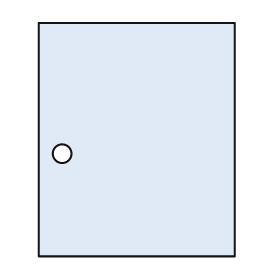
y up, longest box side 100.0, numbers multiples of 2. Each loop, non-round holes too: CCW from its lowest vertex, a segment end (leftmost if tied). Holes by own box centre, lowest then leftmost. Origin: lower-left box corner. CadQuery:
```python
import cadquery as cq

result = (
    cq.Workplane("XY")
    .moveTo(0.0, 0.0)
    .lineTo(84.0, 0.0)
    .lineTo(84.0, 100.0)
    .lineTo(0.0, 100.0)
    .close()
    .moveTo(10.0, 44.0)
    .circle(4.0)
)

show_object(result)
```